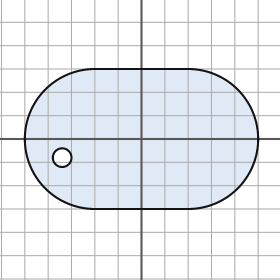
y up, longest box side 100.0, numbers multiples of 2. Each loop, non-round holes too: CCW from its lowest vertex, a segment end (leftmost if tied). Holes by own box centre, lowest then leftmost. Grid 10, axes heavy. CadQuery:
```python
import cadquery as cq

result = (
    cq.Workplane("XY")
    .moveTo(-20.0, -30.0)
    .lineTo(20.0, -30.0)
    .threePointArc((50.0, 0.0), (20.0, 30.0))
    .lineTo(-20.0, 30.0)
    .threePointArc((-50.0, 0.0), (-20.0, -30.0))
    .close()
    .moveTo(-34.0, -8.0)
    .circle(4.0)
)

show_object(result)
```